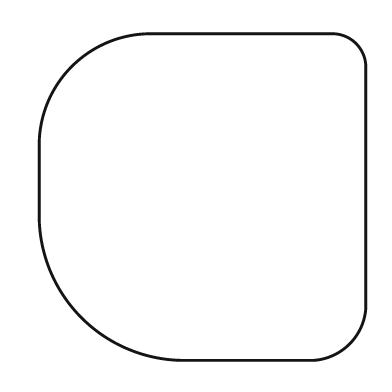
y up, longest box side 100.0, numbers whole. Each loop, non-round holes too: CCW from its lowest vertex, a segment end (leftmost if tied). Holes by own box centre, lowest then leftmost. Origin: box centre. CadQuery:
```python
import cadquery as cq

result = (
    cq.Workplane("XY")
    .moveTo(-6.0, -50.0)
    .lineTo(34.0, -50.0)
    .threePointArc((45.0, -45.0), (50.0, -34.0))
    .lineTo(50.0, 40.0)
    .threePointArc((47.0, 47.0), (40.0, 50.0))
    .lineTo(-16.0, 50.0)
    .threePointArc((-40.0, 40.0), (-50.0, 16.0))
    .lineTo(-50.0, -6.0)
    .threePointArc((-37.0, -37.0), (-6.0, -50.0))
    .close()
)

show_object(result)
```